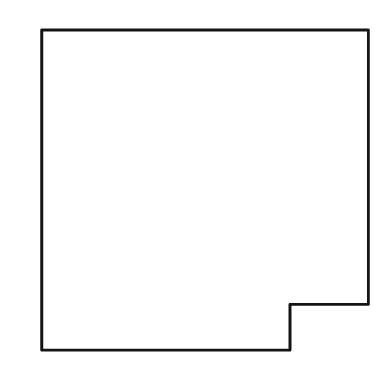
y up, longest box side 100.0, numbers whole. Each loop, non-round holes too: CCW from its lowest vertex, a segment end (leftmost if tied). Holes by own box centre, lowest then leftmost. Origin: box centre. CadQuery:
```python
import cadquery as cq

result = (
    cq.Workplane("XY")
    .moveTo(-50.0, -49.0)
    .lineTo(26.0, -49.0)
    .lineTo(26.0, -35.0)
    .lineTo(50.0, -35.0)
    .lineTo(50.0, 49.0)
    .lineTo(-50.0, 49.0)
    .close()
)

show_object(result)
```